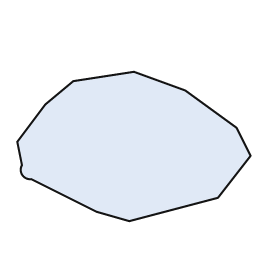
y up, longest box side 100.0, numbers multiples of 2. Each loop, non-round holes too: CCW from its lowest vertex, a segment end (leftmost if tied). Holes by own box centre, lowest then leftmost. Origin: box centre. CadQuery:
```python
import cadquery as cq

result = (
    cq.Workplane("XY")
    .moveTo(-2.0, -32.0)
    .lineTo(36.0, -22.0)
    .lineTo(50.0, -4.0)
    .lineTo(44.0, 8.0)
    .lineTo(22.0, 24.0)
    .lineTo(0.0, 32.0)
    .lineTo(-26.0, 28.0)
    .lineTo(-38.0, 18.0)
    .lineTo(-50.0, 2.0)
    .lineTo(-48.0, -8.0)
    .threePointArc((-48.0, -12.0), (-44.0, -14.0))
    .lineTo(-16.0, -28.0)
    .close()
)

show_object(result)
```